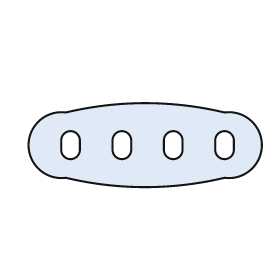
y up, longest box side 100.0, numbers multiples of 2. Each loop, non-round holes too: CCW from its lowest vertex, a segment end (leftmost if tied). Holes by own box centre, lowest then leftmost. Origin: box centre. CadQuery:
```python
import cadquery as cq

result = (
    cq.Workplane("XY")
    .moveTo(-34.0, -14.0)
    .threePointArc((0.0, -18.0), (34.0, -14.0))
    .threePointArc((50.0, 0.0), (34.0, 14.0))
    .threePointArc((0.0, 18.0), (-34.0, 14.0))
    .threePointArc((-50.0, 0.0), (-34.0, -14.0))
    .close()
    .moveTo(-36.0, -2.0)
    .threePointArc((-32.0, -6.0), (-28.0, -2.0))
    .lineTo(-28.0, 2.0)
    .threePointArc((-32.0, 6.0), (-36.0, 2.0))
    .close()
    .moveTo(-14.0, -2.0)
    .threePointArc((-10.0, -6.0), (-6.0, -2.0))
    .lineTo(-6.0, 2.0)
    .threePointArc((-10.0, 6.0), (-14.0, 2.0))
    .close()
    .moveTo(8.0, -2.0)
    .threePointArc((12.0, -6.0), (16.0, -2.0))
    .lineTo(16.0, 2.0)
    .threePointArc((12.0, 6.0), (8.0, 2.0))
    .close()
    .moveTo(30.0, -2.0)
    .threePointArc((34.0, -6.0), (38.0, -2.0))
    .lineTo(38.0, 2.0)
    .threePointArc((34.0, 6.0), (30.0, 2.0))
    .close()
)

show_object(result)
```